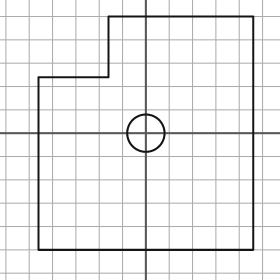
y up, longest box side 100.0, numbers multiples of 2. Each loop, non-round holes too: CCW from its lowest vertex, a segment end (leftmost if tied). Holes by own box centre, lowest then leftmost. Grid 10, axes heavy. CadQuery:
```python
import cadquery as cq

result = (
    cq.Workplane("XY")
    .moveTo(-46.0, -50.0)
    .lineTo(46.0, -50.0)
    .lineTo(46.0, 50.0)
    .lineTo(-16.0, 50.0)
    .lineTo(-16.0, 24.0)
    .lineTo(-46.0, 24.0)
    .close()
    .moveTo(0.0, 0.0)
    .circle(8.0)
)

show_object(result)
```